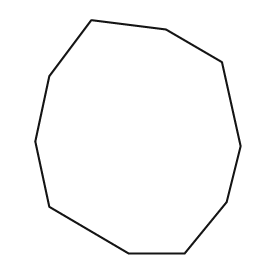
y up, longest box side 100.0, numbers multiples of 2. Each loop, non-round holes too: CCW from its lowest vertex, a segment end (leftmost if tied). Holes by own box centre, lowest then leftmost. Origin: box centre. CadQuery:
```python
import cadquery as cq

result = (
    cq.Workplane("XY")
    .moveTo(-4.0, -50.0)
    .lineTo(20.0, -50.0)
    .lineTo(38.0, -28.0)
    .lineTo(44.0, -4.0)
    .lineTo(36.0, 32.0)
    .lineTo(12.0, 46.0)
    .lineTo(-20.0, 50.0)
    .lineTo(-38.0, 26.0)
    .lineTo(-44.0, -2.0)
    .lineTo(-38.0, -30.0)
    .close()
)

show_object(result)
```